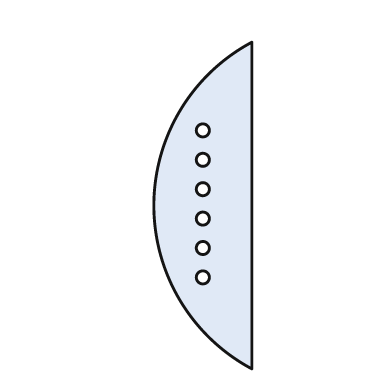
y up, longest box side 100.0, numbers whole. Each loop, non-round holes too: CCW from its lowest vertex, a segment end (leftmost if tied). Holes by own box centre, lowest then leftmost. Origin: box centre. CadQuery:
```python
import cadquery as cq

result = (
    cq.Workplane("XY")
    .moveTo(15.0, -50.0)
    .lineTo(15.0, 50.0)
    .threePointArc((-15.0, 0.0), (15.0, -50.0))
    .close()
    .moveTo(0.0, -22.0)
    .circle(2.0)
    .moveTo(0.0, -13.0)
    .circle(2.0)
    .moveTo(0.0, -4.0)
    .circle(2.0)
    .moveTo(0.0, 5.0)
    .circle(2.0)
    .moveTo(0.0, 14.0)
    .circle(2.0)
    .moveTo(0.0, 23.0)
    .circle(2.0)
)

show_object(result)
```